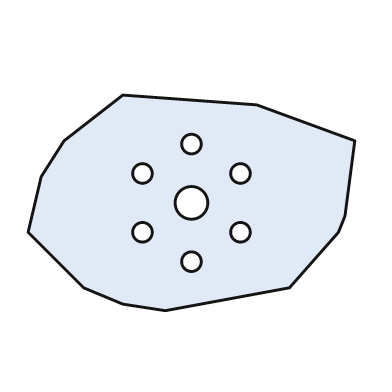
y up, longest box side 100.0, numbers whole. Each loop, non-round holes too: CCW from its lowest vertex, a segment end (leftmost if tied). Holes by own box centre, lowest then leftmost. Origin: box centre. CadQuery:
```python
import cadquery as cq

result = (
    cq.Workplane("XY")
    .moveTo(-8.0, -33.0)
    .lineTo(30.0, -26.0)
    .lineTo(45.0, -9.0)
    .lineTo(47.0, -4.0)
    .lineTo(50.0, 19.0)
    .lineTo(20.0, 30.0)
    .lineTo(-21.0, 33.0)
    .lineTo(-39.0, 19.0)
    .lineTo(-46.0, 8.0)
    .lineTo(-50.0, -9.0)
    .lineTo(-33.0, -26.0)
    .lineTo(-21.0, -31.0)
    .close()
    .moveTo(0.0, -18.0)
    .circle(3.0)
    .moveTo(-15.0, -9.0)
    .circle(3.0)
    .moveTo(15.0, -9.0)
    .circle(3.0)
    .moveTo(0.0, 0.0)
    .circle(5.0)
    .moveTo(-15.0, 9.0)
    .circle(3.0)
    .moveTo(15.0, 9.0)
    .circle(3.0)
    .moveTo(0.0, 18.0)
    .circle(3.0)
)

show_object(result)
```